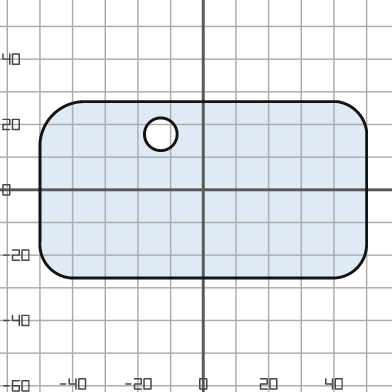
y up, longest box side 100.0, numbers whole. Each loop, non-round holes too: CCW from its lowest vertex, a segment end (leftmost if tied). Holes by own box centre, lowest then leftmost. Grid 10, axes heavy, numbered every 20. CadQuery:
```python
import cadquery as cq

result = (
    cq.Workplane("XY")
    .moveTo(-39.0, -27.0)
    .lineTo(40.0, -27.0)
    .threePointArc((47.0, -24.0), (50.0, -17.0))
    .lineTo(50.0, 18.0)
    .threePointArc((47.0, 24.0), (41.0, 27.0))
    .lineTo(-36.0, 27.0)
    .threePointArc((-46.0, 23.0), (-50.0, 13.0))
    .lineTo(-50.0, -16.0)
    .threePointArc((-47.0, -24.0), (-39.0, -27.0))
    .close()
    .moveTo(-13.0, 17.0)
    .circle(5.0)
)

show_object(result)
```